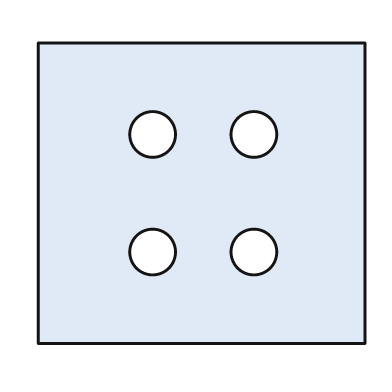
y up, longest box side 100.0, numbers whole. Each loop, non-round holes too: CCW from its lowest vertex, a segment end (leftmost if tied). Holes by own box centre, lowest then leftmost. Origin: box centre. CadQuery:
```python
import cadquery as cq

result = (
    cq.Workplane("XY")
    .moveTo(-50.0, -46.0)
    .lineTo(50.0, -46.0)
    .lineTo(50.0, 46.0)
    .lineTo(-50.0, 46.0)
    .close()
    .moveTo(-15.0, -18.0)
    .circle(7.0)
    .moveTo(16.0, -18.0)
    .circle(7.0)
    .moveTo(-15.0, 18.0)
    .circle(7.0)
    .moveTo(16.0, 18.0)
    .circle(7.0)
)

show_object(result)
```